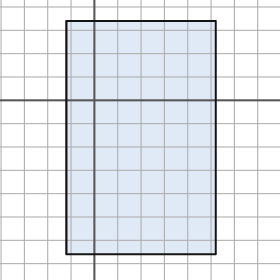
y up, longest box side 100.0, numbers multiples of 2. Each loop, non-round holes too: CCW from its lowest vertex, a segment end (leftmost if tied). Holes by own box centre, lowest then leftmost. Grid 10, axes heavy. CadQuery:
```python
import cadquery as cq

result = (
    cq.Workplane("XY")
    .moveTo(-12.0, -66.0)
    .lineTo(52.0, -66.0)
    .lineTo(52.0, 34.0)
    .lineTo(-12.0, 34.0)
    .close()
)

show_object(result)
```